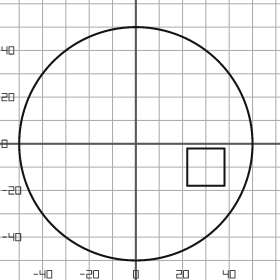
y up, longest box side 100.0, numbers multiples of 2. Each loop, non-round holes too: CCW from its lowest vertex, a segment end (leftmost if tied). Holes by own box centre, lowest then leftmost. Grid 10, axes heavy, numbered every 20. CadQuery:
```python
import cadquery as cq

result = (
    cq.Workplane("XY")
    .moveTo(0.0, 0.0)
    .circle(50.0)
    .moveTo(22.0, -18.0)
    .lineTo(38.0, -18.0)
    .lineTo(38.0, -2.0)
    .lineTo(22.0, -2.0)
    .close()
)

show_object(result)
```